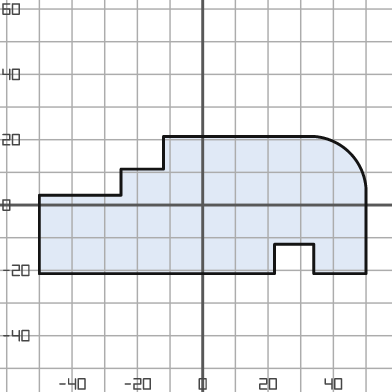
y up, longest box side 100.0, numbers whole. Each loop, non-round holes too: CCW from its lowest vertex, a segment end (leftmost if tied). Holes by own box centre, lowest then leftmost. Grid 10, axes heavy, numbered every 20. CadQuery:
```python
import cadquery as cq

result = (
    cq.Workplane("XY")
    .moveTo(-50.0, -21.0)
    .lineTo(22.0, -21.0)
    .lineTo(22.0, -12.0)
    .lineTo(34.0, -12.0)
    .lineTo(34.0, -21.0)
    .lineTo(50.0, -21.0)
    .lineTo(50.0, 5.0)
    .threePointArc((45.0, 16.0), (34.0, 21.0))
    .lineTo(-12.0, 21.0)
    .lineTo(-12.0, 11.0)
    .lineTo(-25.0, 11.0)
    .lineTo(-25.0, 3.0)
    .lineTo(-50.0, 3.0)
    .close()
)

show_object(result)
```